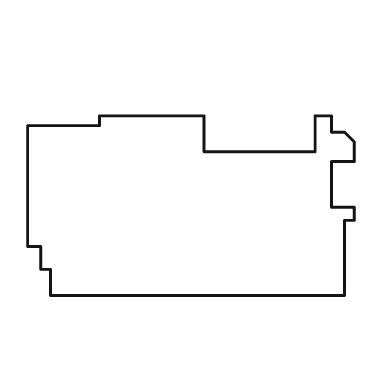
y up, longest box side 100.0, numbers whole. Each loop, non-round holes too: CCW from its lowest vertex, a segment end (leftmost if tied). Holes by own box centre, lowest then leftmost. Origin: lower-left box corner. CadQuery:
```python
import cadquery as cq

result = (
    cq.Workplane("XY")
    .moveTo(7.0, 0.0)
    .lineTo(97.0, 0.0)
    .lineTo(97.0, 23.0)
    .lineTo(100.0, 23.0)
    .lineTo(100.0, 27.0)
    .lineTo(93.0, 27.0)
    .lineTo(93.0, 41.0)
    .lineTo(100.0, 41.0)
    .lineTo(100.0, 47.0)
    .lineTo(97.0, 50.0)
    .lineTo(93.0, 50.0)
    .lineTo(93.0, 55.0)
    .lineTo(88.0, 55.0)
    .lineTo(88.0, 44.0)
    .lineTo(54.0, 44.0)
    .lineTo(54.0, 55.0)
    .lineTo(22.0, 55.0)
    .lineTo(22.0, 52.0)
    .lineTo(0.0, 52.0)
    .lineTo(0.0, 15.0)
    .lineTo(4.0, 15.0)
    .lineTo(4.0, 8.0)
    .lineTo(7.0, 8.0)
    .close()
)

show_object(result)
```